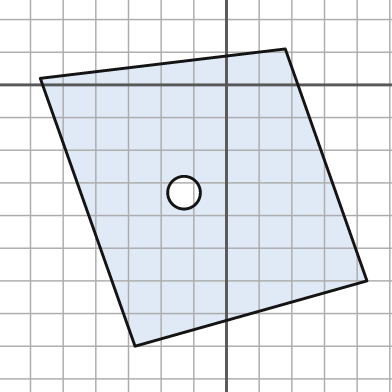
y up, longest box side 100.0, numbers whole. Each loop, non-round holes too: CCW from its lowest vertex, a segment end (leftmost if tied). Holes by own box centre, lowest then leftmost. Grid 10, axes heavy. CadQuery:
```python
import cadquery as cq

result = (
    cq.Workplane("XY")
    .moveTo(-28.0, -80.0)
    .lineTo(43.0, -60.0)
    .lineTo(18.0, 11.0)
    .lineTo(-57.0, 2.0)
    .close()
    .moveTo(-13.0, -33.0)
    .circle(5.0)
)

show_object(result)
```